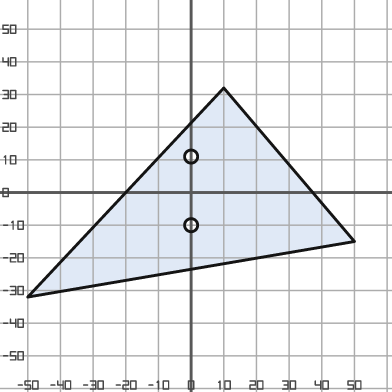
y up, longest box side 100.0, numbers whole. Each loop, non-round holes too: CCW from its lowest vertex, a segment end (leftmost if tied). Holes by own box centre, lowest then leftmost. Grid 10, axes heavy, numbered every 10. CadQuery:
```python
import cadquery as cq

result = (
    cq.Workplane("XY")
    .moveTo(-50.0, -32.0)
    .lineTo(50.0, -15.0)
    .lineTo(10.0, 32.0)
    .close()
    .moveTo(0.0, -10.0)
    .circle(2.0)
    .moveTo(0.0, 11.0)
    .circle(2.0)
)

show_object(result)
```